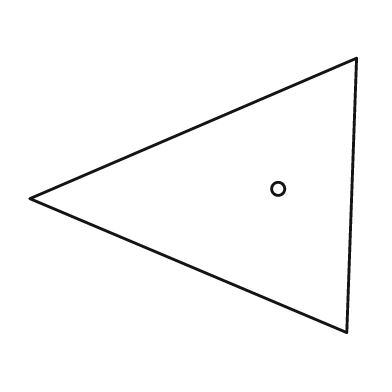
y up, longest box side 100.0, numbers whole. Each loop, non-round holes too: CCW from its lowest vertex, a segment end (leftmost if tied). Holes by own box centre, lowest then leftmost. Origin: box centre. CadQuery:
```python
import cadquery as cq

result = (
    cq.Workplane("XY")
    .moveTo(47.0, -42.0)
    .lineTo(50.0, 42.0)
    .lineTo(-50.0, -1.0)
    .close()
    .moveTo(26.0, 2.0)
    .circle(2.0)
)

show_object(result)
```